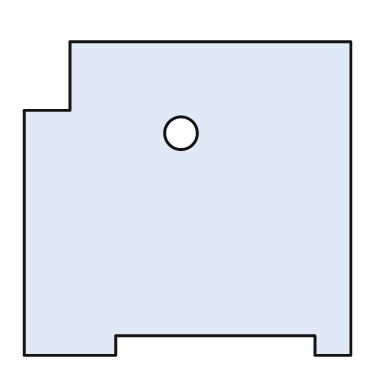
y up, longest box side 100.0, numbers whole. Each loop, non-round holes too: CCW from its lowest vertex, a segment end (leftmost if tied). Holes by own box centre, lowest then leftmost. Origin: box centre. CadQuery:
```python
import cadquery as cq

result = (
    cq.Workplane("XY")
    .moveTo(-50.0, -48.0)
    .lineTo(-22.0, -48.0)
    .lineTo(-22.0, -42.0)
    .lineTo(39.0, -42.0)
    .lineTo(39.0, -48.0)
    .lineTo(50.0, -48.0)
    .lineTo(50.0, 48.0)
    .lineTo(-36.0, 48.0)
    .lineTo(-36.0, 27.0)
    .lineTo(-50.0, 27.0)
    .close()
    .moveTo(-2.0, 20.0)
    .circle(5.0)
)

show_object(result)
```